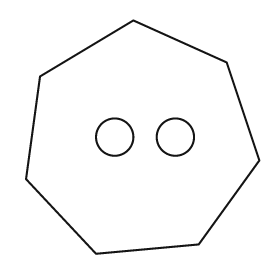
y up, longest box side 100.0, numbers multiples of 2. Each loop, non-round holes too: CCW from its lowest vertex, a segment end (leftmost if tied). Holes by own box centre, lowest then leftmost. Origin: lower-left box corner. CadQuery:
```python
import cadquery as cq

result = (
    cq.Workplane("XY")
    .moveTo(30.0, 0.0)
    .lineTo(74.0, 4.0)
    .lineTo(100.0, 40.0)
    .lineTo(86.0, 82.0)
    .lineTo(46.0, 100.0)
    .lineTo(6.0, 76.0)
    .lineTo(0.0, 32.0)
    .close()
    .moveTo(38.0, 50.0)
    .circle(8.0)
    .moveTo(64.0, 50.0)
    .circle(8.0)
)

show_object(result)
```